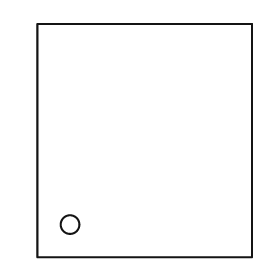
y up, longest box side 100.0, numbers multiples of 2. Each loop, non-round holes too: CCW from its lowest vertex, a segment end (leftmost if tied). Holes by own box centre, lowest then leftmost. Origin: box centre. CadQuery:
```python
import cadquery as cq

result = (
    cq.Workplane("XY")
    .moveTo(-46.0, -50.0)
    .lineTo(46.0, -50.0)
    .lineTo(46.0, 50.0)
    .lineTo(-46.0, 50.0)
    .close()
    .moveTo(-32.0, -36.0)
    .circle(4.0)
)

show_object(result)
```